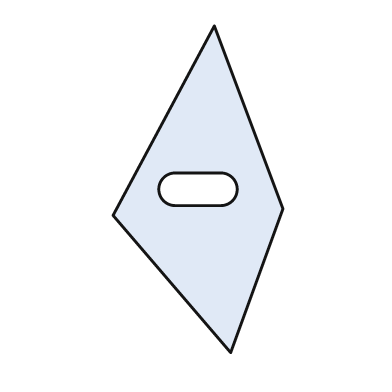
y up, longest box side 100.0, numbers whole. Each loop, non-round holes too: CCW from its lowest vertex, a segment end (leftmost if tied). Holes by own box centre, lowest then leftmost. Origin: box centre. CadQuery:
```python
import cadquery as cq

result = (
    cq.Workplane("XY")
    .moveTo(10.0, -50.0)
    .lineTo(26.0, -6.0)
    .lineTo(5.0, 50.0)
    .lineTo(-26.0, -8.0)
    .close()
    .moveTo(-7.0, -5.0)
    .lineTo(7.0, -5.0)
    .threePointArc((12.0, 0.0), (7.0, 5.0))
    .lineTo(-7.0, 5.0)
    .threePointArc((-12.0, 0.0), (-7.0, -5.0))
    .close()
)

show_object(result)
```